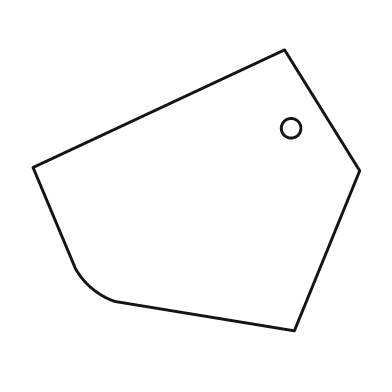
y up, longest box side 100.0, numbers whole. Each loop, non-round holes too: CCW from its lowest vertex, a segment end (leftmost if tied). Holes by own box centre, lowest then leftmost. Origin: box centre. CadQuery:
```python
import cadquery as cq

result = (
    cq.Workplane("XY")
    .moveTo(30.0, -43.0)
    .lineTo(50.0, 6.0)
    .lineTo(27.0, 43.0)
    .lineTo(-50.0, 7.0)
    .lineTo(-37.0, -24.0)
    .threePointArc((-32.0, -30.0), (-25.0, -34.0))
    .close()
    .moveTo(29.0, 19.0)
    .circle(3.0)
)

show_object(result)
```